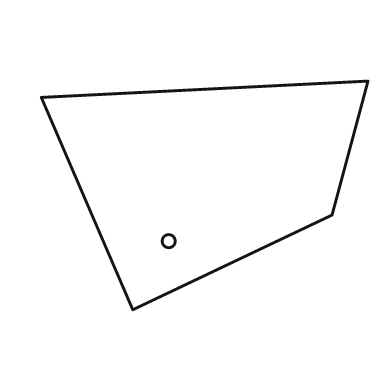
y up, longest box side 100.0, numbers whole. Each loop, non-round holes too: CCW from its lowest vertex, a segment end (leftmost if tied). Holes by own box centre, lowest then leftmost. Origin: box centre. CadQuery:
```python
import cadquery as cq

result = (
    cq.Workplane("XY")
    .moveTo(-22.0, -35.0)
    .lineTo(39.0, -6.0)
    .lineTo(50.0, 35.0)
    .lineTo(-50.0, 30.0)
    .close()
    .moveTo(-11.0, -14.0)
    .circle(2.0)
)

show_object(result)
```